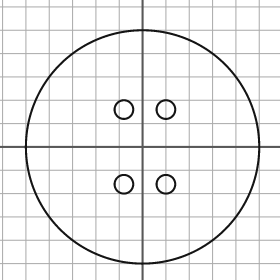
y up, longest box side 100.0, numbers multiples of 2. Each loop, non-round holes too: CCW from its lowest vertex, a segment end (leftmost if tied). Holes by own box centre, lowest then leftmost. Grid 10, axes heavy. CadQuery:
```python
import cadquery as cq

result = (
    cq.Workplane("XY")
    .moveTo(0.0, 0.0)
    .circle(50.0)
    .moveTo(-8.0, -16.0)
    .circle(4.0)
    .moveTo(10.0, -16.0)
    .circle(4.0)
    .moveTo(-8.0, 16.0)
    .circle(4.0)
    .moveTo(10.0, 16.0)
    .circle(4.0)
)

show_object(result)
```